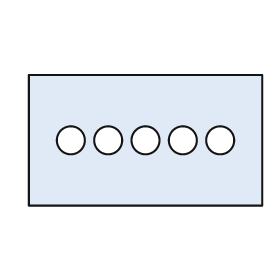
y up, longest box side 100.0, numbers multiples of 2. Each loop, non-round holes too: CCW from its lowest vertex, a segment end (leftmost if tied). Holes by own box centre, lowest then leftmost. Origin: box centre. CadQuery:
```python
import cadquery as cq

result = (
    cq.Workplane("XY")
    .moveTo(-50.0, -28.0)
    .lineTo(50.0, -28.0)
    .lineTo(50.0, 28.0)
    .lineTo(-50.0, 28.0)
    .close()
    .moveTo(-32.0, 0.0)
    .circle(6.0)
    .moveTo(-16.0, 0.0)
    .circle(6.0)
    .moveTo(0.0, 0.0)
    .circle(6.0)
    .moveTo(16.0, 0.0)
    .circle(6.0)
    .moveTo(32.0, 0.0)
    .circle(6.0)
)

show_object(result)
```